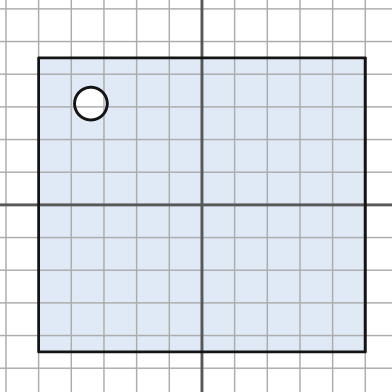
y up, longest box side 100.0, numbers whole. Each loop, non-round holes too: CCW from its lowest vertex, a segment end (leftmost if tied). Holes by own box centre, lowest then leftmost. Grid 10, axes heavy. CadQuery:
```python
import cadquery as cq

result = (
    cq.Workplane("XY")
    .moveTo(-50.0, -45.0)
    .lineTo(50.0, -45.0)
    .lineTo(50.0, 45.0)
    .lineTo(-50.0, 45.0)
    .close()
    .moveTo(-34.0, 31.0)
    .circle(5.0)
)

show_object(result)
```